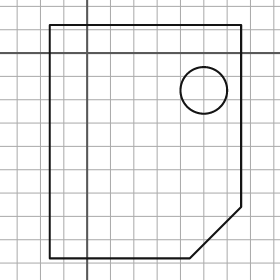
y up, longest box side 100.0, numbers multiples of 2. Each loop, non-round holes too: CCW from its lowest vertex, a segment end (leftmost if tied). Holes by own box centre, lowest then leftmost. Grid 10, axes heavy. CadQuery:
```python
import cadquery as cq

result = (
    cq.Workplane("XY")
    .moveTo(-16.0, -88.0)
    .lineTo(44.0, -88.0)
    .lineTo(66.0, -66.0)
    .lineTo(66.0, 12.0)
    .lineTo(-16.0, 12.0)
    .close()
    .moveTo(50.0, -16.0)
    .circle(10.0)
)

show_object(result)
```